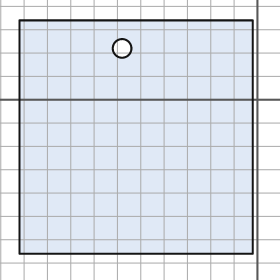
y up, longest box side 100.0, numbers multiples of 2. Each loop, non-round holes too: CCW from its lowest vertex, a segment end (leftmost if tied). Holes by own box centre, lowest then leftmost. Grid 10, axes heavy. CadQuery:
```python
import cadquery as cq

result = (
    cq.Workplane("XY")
    .moveTo(-102.0, -66.0)
    .lineTo(-2.0, -66.0)
    .lineTo(-2.0, 34.0)
    .lineTo(-102.0, 34.0)
    .close()
    .moveTo(-58.0, 22.0)
    .circle(4.0)
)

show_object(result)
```